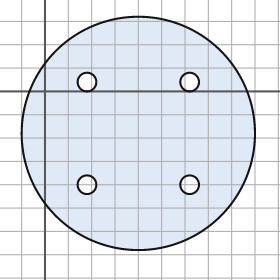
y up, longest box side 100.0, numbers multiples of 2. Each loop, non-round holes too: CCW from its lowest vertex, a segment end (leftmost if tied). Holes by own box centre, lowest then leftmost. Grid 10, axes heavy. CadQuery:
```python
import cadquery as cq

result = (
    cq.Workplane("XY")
    .moveTo(40.0, -18.0)
    .circle(50.0)
    .moveTo(18.0, -40.0)
    .circle(4.0)
    .moveTo(62.0, -40.0)
    .circle(4.0)
    .moveTo(18.0, 4.0)
    .circle(4.0)
    .moveTo(62.0, 4.0)
    .circle(4.0)
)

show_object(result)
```